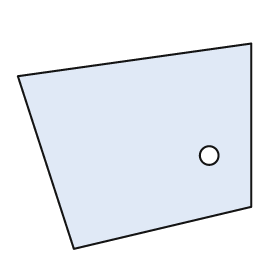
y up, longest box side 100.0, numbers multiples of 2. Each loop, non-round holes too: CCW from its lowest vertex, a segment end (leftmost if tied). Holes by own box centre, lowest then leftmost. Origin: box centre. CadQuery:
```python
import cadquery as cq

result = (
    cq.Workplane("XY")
    .moveTo(-26.0, -44.0)
    .lineTo(50.0, -26.0)
    .lineTo(50.0, 44.0)
    .lineTo(-50.0, 30.0)
    .close()
    .moveTo(32.0, -4.0)
    .circle(4.0)
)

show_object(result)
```